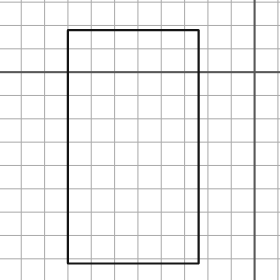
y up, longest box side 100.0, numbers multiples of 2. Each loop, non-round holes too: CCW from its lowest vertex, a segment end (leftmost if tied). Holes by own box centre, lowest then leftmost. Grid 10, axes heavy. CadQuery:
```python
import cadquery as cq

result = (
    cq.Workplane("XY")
    .moveTo(-80.0, -82.0)
    .lineTo(-24.0, -82.0)
    .lineTo(-24.0, 18.0)
    .lineTo(-80.0, 18.0)
    .close()
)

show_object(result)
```